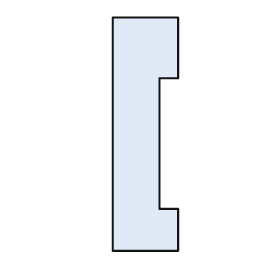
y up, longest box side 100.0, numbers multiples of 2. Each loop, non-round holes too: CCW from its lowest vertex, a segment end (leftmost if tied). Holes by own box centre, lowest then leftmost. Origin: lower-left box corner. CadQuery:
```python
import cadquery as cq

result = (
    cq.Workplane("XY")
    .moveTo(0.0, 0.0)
    .lineTo(28.0, 0.0)
    .lineTo(28.0, 18.0)
    .lineTo(20.0, 18.0)
    .lineTo(20.0, 74.0)
    .lineTo(28.0, 74.0)
    .lineTo(28.0, 100.0)
    .lineTo(0.0, 100.0)
    .close()
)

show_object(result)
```